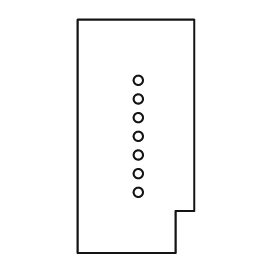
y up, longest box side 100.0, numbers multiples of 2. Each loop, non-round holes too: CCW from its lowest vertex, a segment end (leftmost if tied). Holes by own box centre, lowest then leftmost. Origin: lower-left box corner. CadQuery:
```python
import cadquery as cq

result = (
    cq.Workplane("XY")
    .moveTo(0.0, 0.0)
    .lineTo(42.0, 0.0)
    .lineTo(42.0, 18.0)
    .lineTo(50.0, 18.0)
    .lineTo(50.0, 100.0)
    .lineTo(0.0, 100.0)
    .close()
    .moveTo(26.0, 26.0)
    .circle(2.0)
    .moveTo(26.0, 34.0)
    .circle(2.0)
    .moveTo(26.0, 42.0)
    .circle(2.0)
    .moveTo(26.0, 50.0)
    .circle(2.0)
    .moveTo(26.0, 58.0)
    .circle(2.0)
    .moveTo(26.0, 66.0)
    .circle(2.0)
    .moveTo(26.0, 74.0)
    .circle(2.0)
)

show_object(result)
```